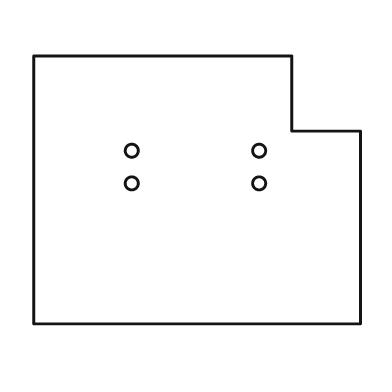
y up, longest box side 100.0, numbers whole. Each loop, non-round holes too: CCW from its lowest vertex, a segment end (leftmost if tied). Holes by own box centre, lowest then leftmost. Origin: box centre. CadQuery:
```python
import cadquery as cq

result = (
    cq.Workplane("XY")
    .moveTo(-50.0, -41.0)
    .lineTo(50.0, -41.0)
    .lineTo(50.0, 18.0)
    .lineTo(29.0, 18.0)
    .lineTo(29.0, 41.0)
    .lineTo(-50.0, 41.0)
    .close()
    .moveTo(-20.0, 2.0)
    .circle(2.0)
    .moveTo(19.0, 2.0)
    .circle(2.0)
    .moveTo(-20.0, 12.0)
    .circle(2.0)
    .moveTo(19.0, 12.0)
    .circle(2.0)
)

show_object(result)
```